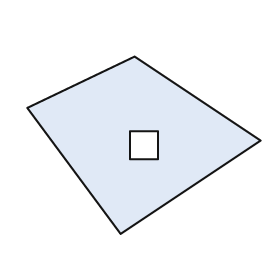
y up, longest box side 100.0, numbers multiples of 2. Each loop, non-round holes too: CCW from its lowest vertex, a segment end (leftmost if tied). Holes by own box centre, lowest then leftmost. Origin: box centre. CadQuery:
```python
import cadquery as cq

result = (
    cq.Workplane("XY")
    .moveTo(-10.0, -38.0)
    .lineTo(50.0, 2.0)
    .lineTo(-4.0, 38.0)
    .lineTo(-50.0, 16.0)
    .close()
    .moveTo(-6.0, -6.0)
    .lineTo(6.0, -6.0)
    .lineTo(6.0, 6.0)
    .lineTo(-6.0, 6.0)
    .close()
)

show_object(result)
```